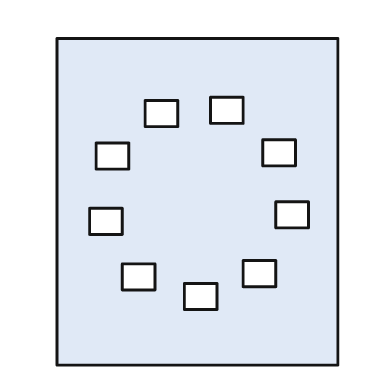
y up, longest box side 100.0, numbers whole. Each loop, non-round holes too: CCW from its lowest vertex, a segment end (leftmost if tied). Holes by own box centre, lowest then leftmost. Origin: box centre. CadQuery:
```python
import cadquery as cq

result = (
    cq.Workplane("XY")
    .moveTo(-43.0, -50.0)
    .lineTo(43.0, -50.0)
    .lineTo(43.0, 50.0)
    .lineTo(-43.0, 50.0)
    .close()
    .moveTo(-4.0, -33.0)
    .lineTo(6.0, -33.0)
    .lineTo(6.0, -25.0)
    .lineTo(-4.0, -25.0)
    .close()
    .moveTo(-23.0, -27.0)
    .lineTo(-13.0, -27.0)
    .lineTo(-13.0, -19.0)
    .lineTo(-23.0, -19.0)
    .close()
    .moveTo(14.0, -26.0)
    .lineTo(24.0, -26.0)
    .lineTo(24.0, -18.0)
    .lineTo(14.0, -18.0)
    .close()
    .moveTo(-33.0, -10.0)
    .lineTo(-23.0, -10.0)
    .lineTo(-23.0, -2.0)
    .lineTo(-33.0, -2.0)
    .close()
    .moveTo(24.0, -8.0)
    .lineTo(34.0, -8.0)
    .lineTo(34.0, 0.0)
    .lineTo(24.0, 0.0)
    .close()
    .moveTo(-31.0, 10.0)
    .lineTo(-21.0, 10.0)
    .lineTo(-21.0, 18.0)
    .lineTo(-31.0, 18.0)
    .close()
    .moveTo(20.0, 11.0)
    .lineTo(30.0, 11.0)
    .lineTo(30.0, 19.0)
    .lineTo(20.0, 19.0)
    .close()
    .moveTo(-16.0, 23.0)
    .lineTo(-6.0, 23.0)
    .lineTo(-6.0, 31.0)
    .lineTo(-16.0, 31.0)
    .close()
    .moveTo(4.0, 24.0)
    .lineTo(14.0, 24.0)
    .lineTo(14.0, 32.0)
    .lineTo(4.0, 32.0)
    .close()
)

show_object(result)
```